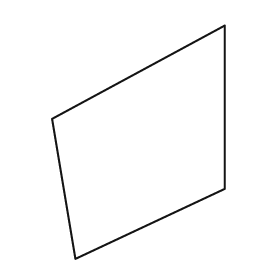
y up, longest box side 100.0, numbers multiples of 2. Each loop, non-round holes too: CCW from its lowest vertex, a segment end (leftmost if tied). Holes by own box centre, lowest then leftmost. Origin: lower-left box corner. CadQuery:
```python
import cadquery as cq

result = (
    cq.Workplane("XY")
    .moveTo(10.0, 0.0)
    .lineTo(74.0, 30.0)
    .lineTo(74.0, 100.0)
    .lineTo(0.0, 60.0)
    .close()
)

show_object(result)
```